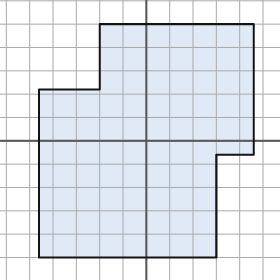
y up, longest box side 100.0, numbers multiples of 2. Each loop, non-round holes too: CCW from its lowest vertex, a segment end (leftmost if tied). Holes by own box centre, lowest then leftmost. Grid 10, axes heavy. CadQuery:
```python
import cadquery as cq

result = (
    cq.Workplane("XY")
    .moveTo(-46.0, -50.0)
    .lineTo(30.0, -50.0)
    .lineTo(30.0, -6.0)
    .lineTo(46.0, -6.0)
    .lineTo(46.0, 50.0)
    .lineTo(-20.0, 50.0)
    .lineTo(-20.0, 22.0)
    .lineTo(-46.0, 22.0)
    .close()
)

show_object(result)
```